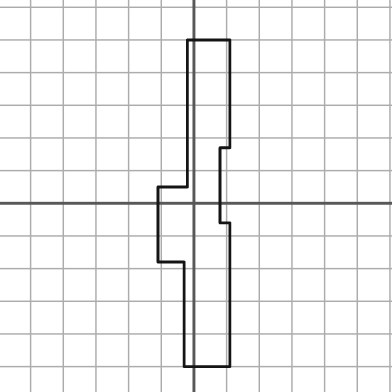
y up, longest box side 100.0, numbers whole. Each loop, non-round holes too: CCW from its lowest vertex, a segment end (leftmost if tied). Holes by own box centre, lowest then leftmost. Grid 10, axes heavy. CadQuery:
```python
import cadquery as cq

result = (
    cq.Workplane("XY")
    .moveTo(-3.0, -50.0)
    .lineTo(11.0, -50.0)
    .lineTo(11.0, -6.0)
    .lineTo(8.0, -6.0)
    .lineTo(8.0, 17.0)
    .lineTo(11.0, 17.0)
    .lineTo(11.0, 50.0)
    .lineTo(-2.0, 50.0)
    .lineTo(-2.0, 5.0)
    .lineTo(-11.0, 5.0)
    .lineTo(-11.0, -18.0)
    .lineTo(-3.0, -18.0)
    .close()
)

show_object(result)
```